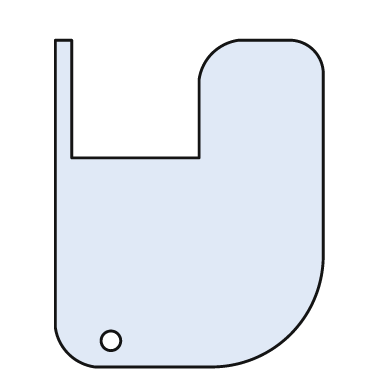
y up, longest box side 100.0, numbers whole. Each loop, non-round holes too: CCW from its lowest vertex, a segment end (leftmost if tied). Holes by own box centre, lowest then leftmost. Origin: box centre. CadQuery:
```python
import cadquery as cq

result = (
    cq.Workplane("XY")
    .moveTo(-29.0, -50.0)
    .lineTo(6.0, -50.0)
    .threePointArc((31.0, -40.0), (41.0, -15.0))
    .lineTo(41.0, 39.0)
    .threePointArc((38.0, 47.0), (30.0, 50.0))
    .lineTo(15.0, 50.0)
    .threePointArc((7.0, 46.0), (3.0, 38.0))
    .lineTo(3.0, 14.0)
    .lineTo(-36.0, 14.0)
    .lineTo(-36.0, 50.0)
    .lineTo(-41.0, 50.0)
    .lineTo(-41.0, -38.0)
    .threePointArc((-37.0, -46.0), (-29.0, -50.0))
    .close()
    .moveTo(-24.0, -42.0)
    .circle(3.0)
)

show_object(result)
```